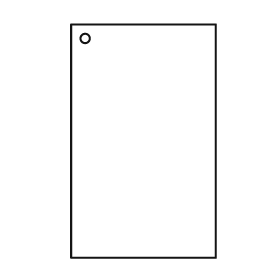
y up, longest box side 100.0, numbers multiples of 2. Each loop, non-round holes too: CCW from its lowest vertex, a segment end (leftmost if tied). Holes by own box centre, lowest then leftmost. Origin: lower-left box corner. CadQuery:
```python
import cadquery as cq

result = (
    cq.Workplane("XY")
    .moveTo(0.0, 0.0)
    .lineTo(62.0, 0.0)
    .lineTo(62.0, 100.0)
    .lineTo(0.0, 100.0)
    .close()
    .moveTo(6.0, 94.0)
    .circle(2.0)
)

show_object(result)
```